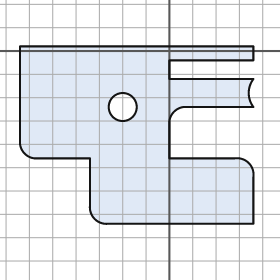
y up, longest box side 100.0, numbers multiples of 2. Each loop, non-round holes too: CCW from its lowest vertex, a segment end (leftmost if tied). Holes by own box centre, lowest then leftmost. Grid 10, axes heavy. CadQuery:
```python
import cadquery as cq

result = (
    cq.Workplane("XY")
    .moveTo(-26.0, -74.0)
    .lineTo(36.0, -74.0)
    .lineTo(36.0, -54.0)
    .threePointArc((34.0, -48.0), (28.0, -46.0))
    .lineTo(0.0, -46.0)
    .lineTo(0.0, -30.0)
    .threePointArc((2.0, -26.0), (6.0, -24.0))
    .lineTo(36.0, -24.0)
    .threePointArc((34.0, -18.0), (36.0, -12.0))
    .lineTo(0.0, -12.0)
    .lineTo(0.0, -4.0)
    .lineTo(36.0, -4.0)
    .lineTo(36.0, 2.0)
    .lineTo(-64.0, 2.0)
    .lineTo(-64.0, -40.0)
    .threePointArc((-62.0, -44.0), (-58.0, -46.0))
    .lineTo(-34.0, -46.0)
    .lineTo(-34.0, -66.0)
    .threePointArc((-32.0, -72.0), (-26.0, -74.0))
    .close()
    .moveTo(-20.0, -24.0)
    .circle(6.0)
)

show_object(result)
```